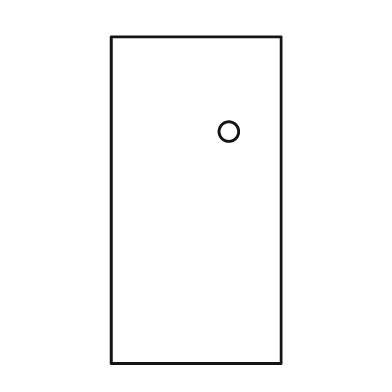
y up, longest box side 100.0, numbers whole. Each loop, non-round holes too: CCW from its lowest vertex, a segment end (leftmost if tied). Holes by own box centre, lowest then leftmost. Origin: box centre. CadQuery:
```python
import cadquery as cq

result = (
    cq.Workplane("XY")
    .moveTo(-26.0, -50.0)
    .lineTo(26.0, -50.0)
    .lineTo(26.0, 50.0)
    .lineTo(-26.0, 50.0)
    .close()
    .moveTo(10.0, 21.0)
    .circle(3.0)
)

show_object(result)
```